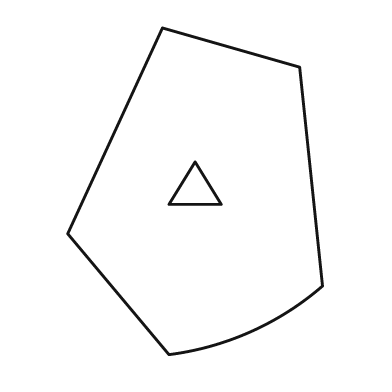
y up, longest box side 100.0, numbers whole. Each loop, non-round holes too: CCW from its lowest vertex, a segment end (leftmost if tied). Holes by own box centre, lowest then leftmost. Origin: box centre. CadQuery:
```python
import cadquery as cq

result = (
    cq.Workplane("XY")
    .moveTo(-8.0, -50.0)
    .threePointArc((17.0, -43.0), (39.0, -29.0))
    .lineTo(32.0, 38.0)
    .lineTo(-10.0, 50.0)
    .lineTo(-39.0, -13.0)
    .close()
    .moveTo(-8.0, -4.0)
    .lineTo(8.0, -4.0)
    .lineTo(0.0, 9.0)
    .close()
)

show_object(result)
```